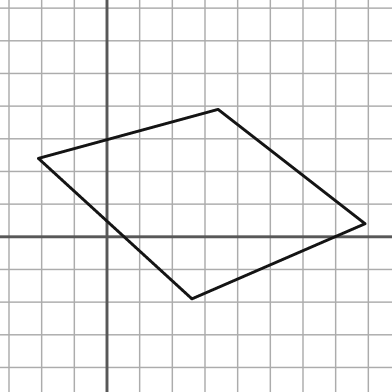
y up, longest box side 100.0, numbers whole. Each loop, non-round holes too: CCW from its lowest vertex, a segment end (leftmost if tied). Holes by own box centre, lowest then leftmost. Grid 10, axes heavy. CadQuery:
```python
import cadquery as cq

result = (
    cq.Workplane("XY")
    .moveTo(26.0, -19.0)
    .lineTo(79.0, 4.0)
    .lineTo(34.0, 39.0)
    .lineTo(-21.0, 24.0)
    .close()
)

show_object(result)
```